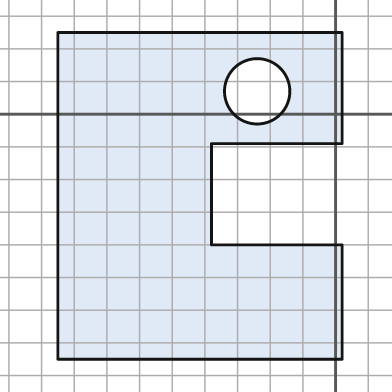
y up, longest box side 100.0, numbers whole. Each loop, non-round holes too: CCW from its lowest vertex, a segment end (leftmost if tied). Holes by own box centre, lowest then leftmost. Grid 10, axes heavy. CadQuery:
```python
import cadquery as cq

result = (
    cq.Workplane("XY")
    .moveTo(-85.0, -75.0)
    .lineTo(2.0, -75.0)
    .lineTo(2.0, -40.0)
    .lineTo(-38.0, -40.0)
    .lineTo(-38.0, -9.0)
    .lineTo(2.0, -9.0)
    .lineTo(2.0, 25.0)
    .lineTo(-85.0, 25.0)
    .close()
    .moveTo(-24.0, 7.0)
    .circle(10.0)
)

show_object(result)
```